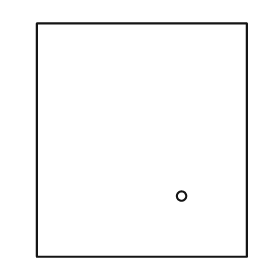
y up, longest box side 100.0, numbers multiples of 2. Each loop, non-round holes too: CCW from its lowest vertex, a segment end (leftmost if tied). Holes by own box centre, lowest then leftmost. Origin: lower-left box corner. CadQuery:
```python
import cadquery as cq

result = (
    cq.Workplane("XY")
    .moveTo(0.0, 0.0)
    .lineTo(90.0, 0.0)
    .lineTo(90.0, 100.0)
    .lineTo(0.0, 100.0)
    .close()
    .moveTo(62.0, 26.0)
    .circle(2.0)
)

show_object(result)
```